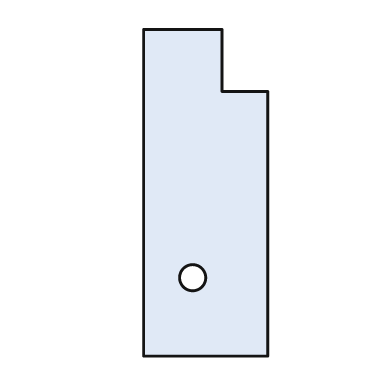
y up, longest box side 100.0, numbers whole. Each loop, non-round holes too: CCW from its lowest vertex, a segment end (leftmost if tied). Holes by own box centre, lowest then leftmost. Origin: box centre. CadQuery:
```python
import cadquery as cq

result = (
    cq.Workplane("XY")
    .moveTo(-19.0, -50.0)
    .lineTo(19.0, -50.0)
    .lineTo(19.0, 31.0)
    .lineTo(5.0, 31.0)
    .lineTo(5.0, 50.0)
    .lineTo(-19.0, 50.0)
    .close()
    .moveTo(-4.0, -26.0)
    .circle(4.0)
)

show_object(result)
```